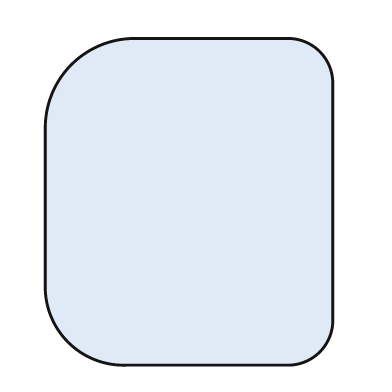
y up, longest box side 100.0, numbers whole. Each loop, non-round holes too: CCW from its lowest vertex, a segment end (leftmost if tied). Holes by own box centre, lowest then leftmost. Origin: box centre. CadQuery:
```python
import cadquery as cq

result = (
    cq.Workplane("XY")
    .moveTo(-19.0, -50.0)
    .lineTo(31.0, -50.0)
    .threePointArc((40.0, -46.0), (44.0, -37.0))
    .lineTo(44.0, 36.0)
    .threePointArc((40.0, 46.0), (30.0, 50.0))
    .lineTo(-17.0, 50.0)
    .threePointArc((-36.0, 42.0), (-44.0, 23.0))
    .lineTo(-44.0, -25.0)
    .threePointArc((-37.0, -43.0), (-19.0, -50.0))
    .close()
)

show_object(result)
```